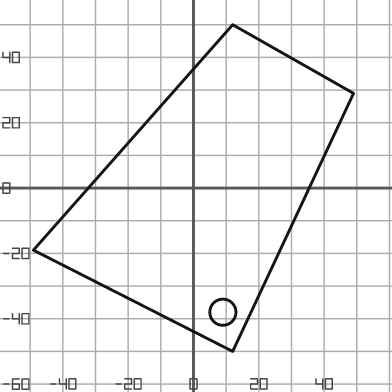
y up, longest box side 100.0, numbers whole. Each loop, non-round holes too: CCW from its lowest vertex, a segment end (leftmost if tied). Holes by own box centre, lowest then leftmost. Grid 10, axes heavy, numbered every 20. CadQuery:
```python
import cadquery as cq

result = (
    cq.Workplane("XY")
    .moveTo(12.0, -50.0)
    .lineTo(49.0, 29.0)
    .lineTo(12.0, 50.0)
    .lineTo(-49.0, -19.0)
    .close()
    .moveTo(9.0, -38.0)
    .circle(4.0)
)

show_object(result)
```